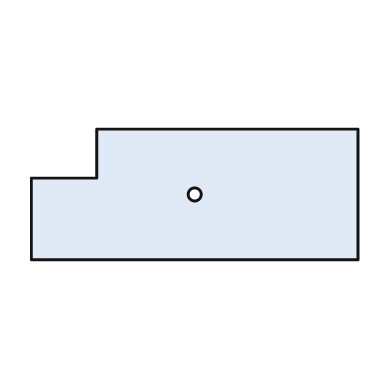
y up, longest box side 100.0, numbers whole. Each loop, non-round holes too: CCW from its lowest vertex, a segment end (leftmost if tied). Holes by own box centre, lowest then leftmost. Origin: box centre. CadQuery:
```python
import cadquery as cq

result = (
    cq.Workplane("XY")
    .moveTo(-50.0, -20.0)
    .lineTo(50.0, -20.0)
    .lineTo(50.0, 20.0)
    .lineTo(-30.0, 20.0)
    .lineTo(-30.0, 5.0)
    .lineTo(-50.0, 5.0)
    .close()
    .moveTo(0.0, 0.0)
    .circle(2.0)
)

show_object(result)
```